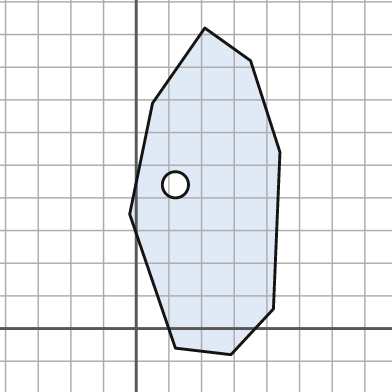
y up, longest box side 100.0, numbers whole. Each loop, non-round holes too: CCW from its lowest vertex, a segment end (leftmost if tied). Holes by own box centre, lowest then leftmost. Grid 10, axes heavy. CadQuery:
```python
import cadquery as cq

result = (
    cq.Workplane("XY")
    .moveTo(29.0, -8.0)
    .lineTo(42.0, 6.0)
    .lineTo(44.0, 54.0)
    .lineTo(35.0, 82.0)
    .lineTo(21.0, 92.0)
    .lineTo(5.0, 69.0)
    .lineTo(-2.0, 35.0)
    .lineTo(12.0, -6.0)
    .close()
    .moveTo(12.0, 44.0)
    .circle(4.0)
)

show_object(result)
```